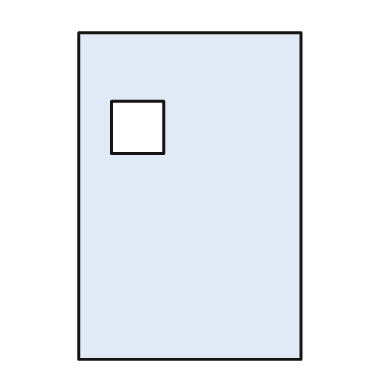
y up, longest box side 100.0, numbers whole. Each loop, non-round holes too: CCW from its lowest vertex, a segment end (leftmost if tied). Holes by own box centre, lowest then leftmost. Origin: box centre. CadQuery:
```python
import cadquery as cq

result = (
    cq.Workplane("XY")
    .moveTo(-34.0, -50.0)
    .lineTo(34.0, -50.0)
    .lineTo(34.0, 50.0)
    .lineTo(-34.0, 50.0)
    .close()
    .moveTo(-24.0, 13.0)
    .lineTo(-8.0, 13.0)
    .lineTo(-8.0, 29.0)
    .lineTo(-24.0, 29.0)
    .close()
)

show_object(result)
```